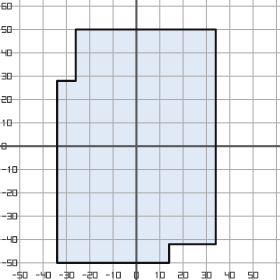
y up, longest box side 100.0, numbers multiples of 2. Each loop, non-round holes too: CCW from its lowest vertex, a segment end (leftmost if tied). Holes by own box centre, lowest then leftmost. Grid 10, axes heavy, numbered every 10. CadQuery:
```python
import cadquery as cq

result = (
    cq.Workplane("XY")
    .moveTo(-34.0, -50.0)
    .lineTo(14.0, -50.0)
    .lineTo(14.0, -42.0)
    .lineTo(34.0, -42.0)
    .lineTo(34.0, 50.0)
    .lineTo(-26.0, 50.0)
    .lineTo(-26.0, 28.0)
    .lineTo(-34.0, 28.0)
    .close()
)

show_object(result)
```